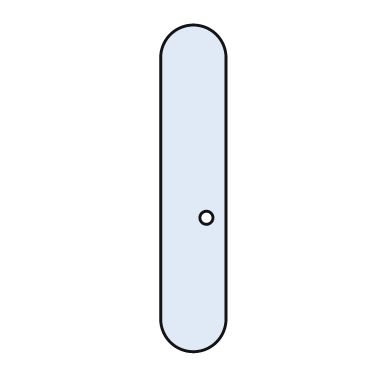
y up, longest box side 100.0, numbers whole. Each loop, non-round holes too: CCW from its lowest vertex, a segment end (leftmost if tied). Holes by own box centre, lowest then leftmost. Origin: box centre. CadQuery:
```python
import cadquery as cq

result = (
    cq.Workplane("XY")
    .moveTo(-10.0, -40.0)
    .threePointArc((0.0, -50.0), (10.0, -40.0))
    .lineTo(10.0, 40.0)
    .threePointArc((0.0, 50.0), (-10.0, 40.0))
    .close()
    .moveTo(4.0, -9.0)
    .circle(2.0)
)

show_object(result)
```